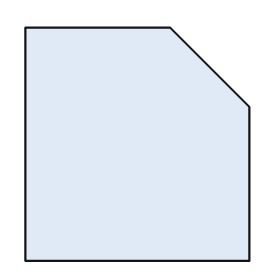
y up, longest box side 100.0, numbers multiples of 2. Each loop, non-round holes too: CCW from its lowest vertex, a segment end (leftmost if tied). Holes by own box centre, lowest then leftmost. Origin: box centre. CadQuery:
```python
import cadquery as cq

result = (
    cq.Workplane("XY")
    .moveTo(-48.0, -50.0)
    .lineTo(48.0, -50.0)
    .lineTo(48.0, 16.0)
    .lineTo(14.0, 50.0)
    .lineTo(-48.0, 50.0)
    .close()
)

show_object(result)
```